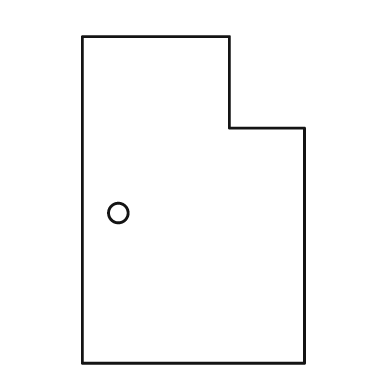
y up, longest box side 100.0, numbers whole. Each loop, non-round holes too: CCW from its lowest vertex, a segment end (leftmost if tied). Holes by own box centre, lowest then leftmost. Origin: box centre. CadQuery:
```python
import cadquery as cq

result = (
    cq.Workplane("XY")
    .moveTo(-34.0, -50.0)
    .lineTo(34.0, -50.0)
    .lineTo(34.0, 22.0)
    .lineTo(11.0, 22.0)
    .lineTo(11.0, 50.0)
    .lineTo(-34.0, 50.0)
    .close()
    .moveTo(-23.0, -4.0)
    .circle(3.0)
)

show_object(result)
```